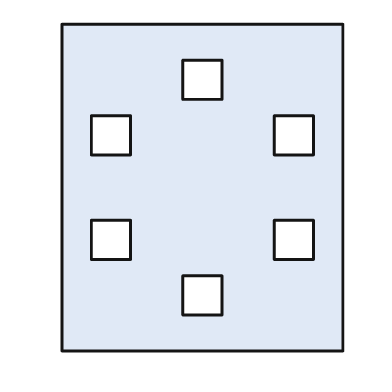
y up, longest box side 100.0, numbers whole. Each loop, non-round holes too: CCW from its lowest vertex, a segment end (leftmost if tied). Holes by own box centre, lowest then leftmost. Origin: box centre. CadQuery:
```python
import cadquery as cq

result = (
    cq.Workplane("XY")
    .moveTo(-43.0, -50.0)
    .lineTo(43.0, -50.0)
    .lineTo(43.0, 50.0)
    .lineTo(-43.0, 50.0)
    .close()
    .moveTo(-6.0, -39.0)
    .lineTo(6.0, -39.0)
    .lineTo(6.0, -27.0)
    .lineTo(-6.0, -27.0)
    .close()
    .moveTo(-34.0, -22.0)
    .lineTo(-22.0, -22.0)
    .lineTo(-22.0, -10.0)
    .lineTo(-34.0, -10.0)
    .close()
    .moveTo(22.0, -22.0)
    .lineTo(34.0, -22.0)
    .lineTo(34.0, -10.0)
    .lineTo(22.0, -10.0)
    .close()
    .moveTo(-34.0, 10.0)
    .lineTo(-22.0, 10.0)
    .lineTo(-22.0, 22.0)
    .lineTo(-34.0, 22.0)
    .close()
    .moveTo(22.0, 10.0)
    .lineTo(34.0, 10.0)
    .lineTo(34.0, 22.0)
    .lineTo(22.0, 22.0)
    .close()
    .moveTo(-6.0, 27.0)
    .lineTo(6.0, 27.0)
    .lineTo(6.0, 39.0)
    .lineTo(-6.0, 39.0)
    .close()
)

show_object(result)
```